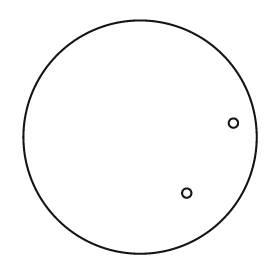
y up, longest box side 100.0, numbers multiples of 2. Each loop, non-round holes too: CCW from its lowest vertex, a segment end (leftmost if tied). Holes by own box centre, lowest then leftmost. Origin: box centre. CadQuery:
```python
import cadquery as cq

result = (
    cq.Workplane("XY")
    .moveTo(0.0, 0.0)
    .circle(50.0)
    .moveTo(20.0, -24.0)
    .circle(2.0)
    .moveTo(40.0, 6.0)
    .circle(2.0)
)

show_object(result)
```